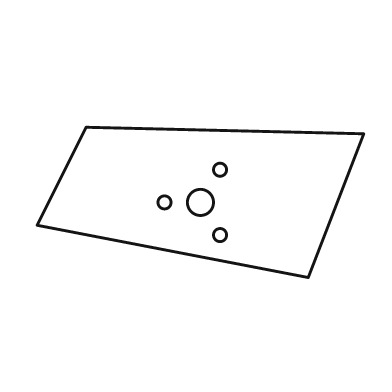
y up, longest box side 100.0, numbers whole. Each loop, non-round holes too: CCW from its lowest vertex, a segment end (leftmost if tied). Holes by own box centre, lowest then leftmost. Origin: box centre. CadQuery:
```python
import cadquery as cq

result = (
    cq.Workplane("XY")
    .moveTo(33.0, -23.0)
    .lineTo(50.0, 21.0)
    .lineTo(-35.0, 23.0)
    .lineTo(-50.0, -7.0)
    .close()
    .moveTo(6.0, -10.0)
    .circle(2.0)
    .moveTo(-11.0, 0.0)
    .circle(2.0)
    .moveTo(0.0, 0.0)
    .circle(4.0)
    .moveTo(6.0, 10.0)
    .circle(2.0)
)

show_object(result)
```